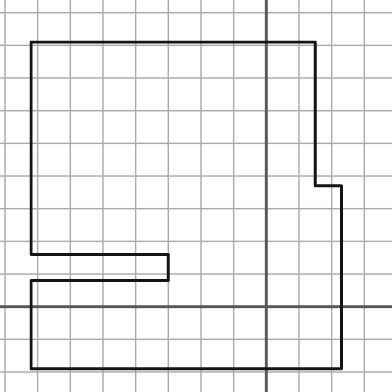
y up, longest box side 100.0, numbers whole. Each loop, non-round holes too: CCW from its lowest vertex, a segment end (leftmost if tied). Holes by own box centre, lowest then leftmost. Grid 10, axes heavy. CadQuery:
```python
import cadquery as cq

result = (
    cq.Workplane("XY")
    .moveTo(-72.0, -19.0)
    .lineTo(23.0, -19.0)
    .lineTo(23.0, 37.0)
    .lineTo(15.0, 37.0)
    .lineTo(15.0, 81.0)
    .lineTo(-72.0, 81.0)
    .lineTo(-72.0, 16.0)
    .lineTo(-30.0, 16.0)
    .lineTo(-30.0, 8.0)
    .lineTo(-72.0, 8.0)
    .close()
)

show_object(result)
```